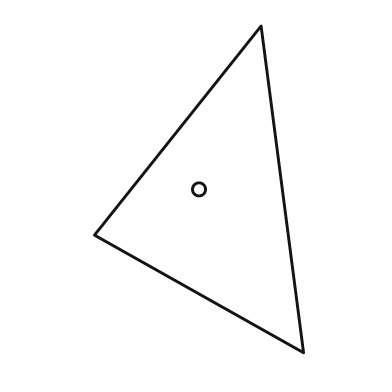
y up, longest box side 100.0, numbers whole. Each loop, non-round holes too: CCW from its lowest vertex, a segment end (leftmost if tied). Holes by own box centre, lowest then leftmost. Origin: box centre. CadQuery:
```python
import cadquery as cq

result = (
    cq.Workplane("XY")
    .moveTo(32.0, -50.0)
    .lineTo(19.0, 50.0)
    .lineTo(-32.0, -14.0)
    .close()
    .moveTo(0.0, 0.0)
    .circle(2.0)
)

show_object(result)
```